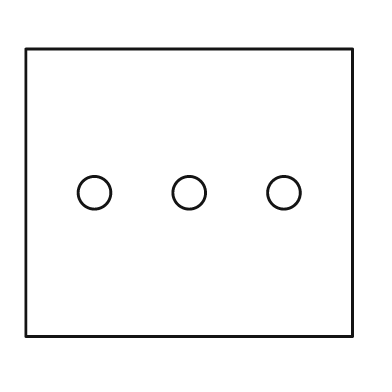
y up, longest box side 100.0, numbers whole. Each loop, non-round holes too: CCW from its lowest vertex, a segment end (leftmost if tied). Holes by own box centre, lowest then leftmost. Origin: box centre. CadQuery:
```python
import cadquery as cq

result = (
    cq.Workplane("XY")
    .moveTo(-50.0, -44.0)
    .lineTo(50.0, -44.0)
    .lineTo(50.0, 44.0)
    .lineTo(-50.0, 44.0)
    .close()
    .moveTo(-29.0, 0.0)
    .circle(5.0)
    .moveTo(0.0, 0.0)
    .circle(5.0)
    .moveTo(29.0, 0.0)
    .circle(5.0)
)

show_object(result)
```